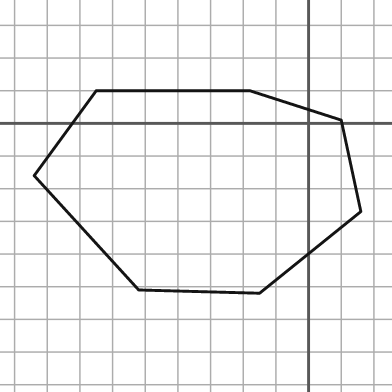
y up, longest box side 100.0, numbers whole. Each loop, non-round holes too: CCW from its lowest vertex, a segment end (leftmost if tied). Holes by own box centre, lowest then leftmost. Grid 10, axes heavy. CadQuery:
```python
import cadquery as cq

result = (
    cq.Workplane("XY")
    .moveTo(-15.0, -52.0)
    .lineTo(16.0, -27.0)
    .lineTo(10.0, 1.0)
    .lineTo(-18.0, 10.0)
    .lineTo(-65.0, 10.0)
    .lineTo(-84.0, -16.0)
    .lineTo(-52.0, -51.0)
    .close()
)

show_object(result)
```